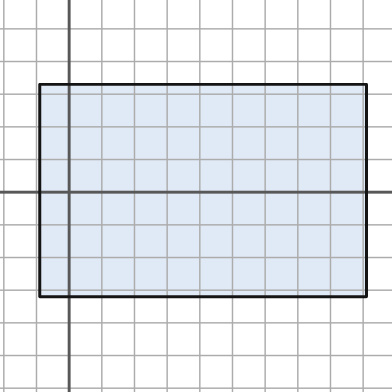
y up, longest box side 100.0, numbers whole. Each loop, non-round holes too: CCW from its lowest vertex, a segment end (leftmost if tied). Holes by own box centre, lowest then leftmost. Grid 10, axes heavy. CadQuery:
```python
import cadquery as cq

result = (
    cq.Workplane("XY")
    .moveTo(-9.0, -32.0)
    .lineTo(91.0, -32.0)
    .lineTo(91.0, 33.0)
    .lineTo(-9.0, 33.0)
    .close()
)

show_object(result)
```